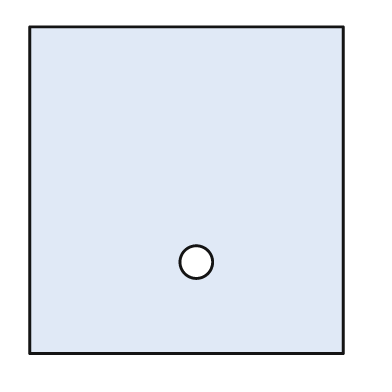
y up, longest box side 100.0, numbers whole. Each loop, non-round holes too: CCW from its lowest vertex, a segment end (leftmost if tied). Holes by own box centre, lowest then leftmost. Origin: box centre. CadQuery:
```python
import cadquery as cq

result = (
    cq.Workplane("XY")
    .moveTo(-48.0, -50.0)
    .lineTo(48.0, -50.0)
    .lineTo(48.0, 50.0)
    .lineTo(-48.0, 50.0)
    .close()
    .moveTo(3.0, -22.0)
    .circle(5.0)
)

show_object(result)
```